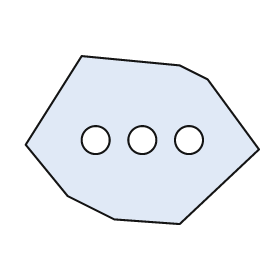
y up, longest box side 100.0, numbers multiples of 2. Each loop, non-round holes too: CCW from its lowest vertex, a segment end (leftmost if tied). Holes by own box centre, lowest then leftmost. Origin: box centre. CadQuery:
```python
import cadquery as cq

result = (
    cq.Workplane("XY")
    .moveTo(16.0, -36.0)
    .lineTo(50.0, -4.0)
    .lineTo(28.0, 26.0)
    .lineTo(16.0, 32.0)
    .lineTo(-26.0, 36.0)
    .lineTo(-50.0, -2.0)
    .lineTo(-32.0, -24.0)
    .lineTo(-12.0, -34.0)
    .close()
    .moveTo(-20.0, 0.0)
    .circle(6.0)
    .moveTo(0.0, 0.0)
    .circle(6.0)
    .moveTo(20.0, 0.0)
    .circle(6.0)
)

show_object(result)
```